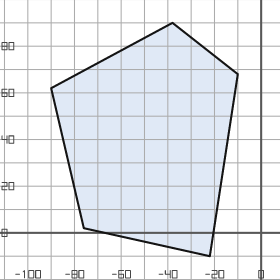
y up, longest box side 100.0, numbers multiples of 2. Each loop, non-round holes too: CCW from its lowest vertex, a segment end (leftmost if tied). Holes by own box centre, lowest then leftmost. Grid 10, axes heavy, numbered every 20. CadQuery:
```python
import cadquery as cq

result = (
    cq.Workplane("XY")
    .moveTo(-22.0, -10.0)
    .lineTo(-10.0, 68.0)
    .lineTo(-38.0, 90.0)
    .lineTo(-90.0, 62.0)
    .lineTo(-76.0, 2.0)
    .close()
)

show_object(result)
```